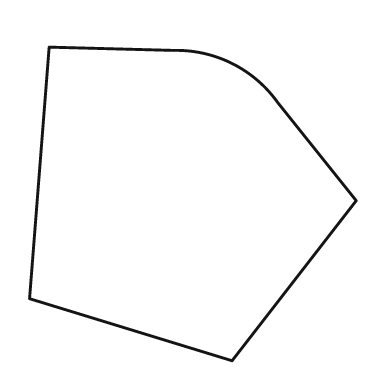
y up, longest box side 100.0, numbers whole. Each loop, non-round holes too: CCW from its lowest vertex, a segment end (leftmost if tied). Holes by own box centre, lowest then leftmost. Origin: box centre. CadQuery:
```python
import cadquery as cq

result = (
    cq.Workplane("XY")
    .moveTo(12.0, -48.0)
    .lineTo(50.0, 1.0)
    .lineTo(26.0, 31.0)
    .threePointArc((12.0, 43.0), (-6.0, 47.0))
    .lineTo(-44.0, 48.0)
    .lineTo(-50.0, -29.0)
    .close()
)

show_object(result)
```